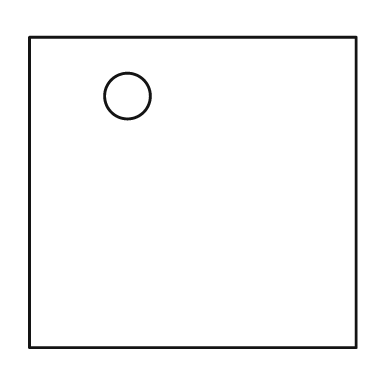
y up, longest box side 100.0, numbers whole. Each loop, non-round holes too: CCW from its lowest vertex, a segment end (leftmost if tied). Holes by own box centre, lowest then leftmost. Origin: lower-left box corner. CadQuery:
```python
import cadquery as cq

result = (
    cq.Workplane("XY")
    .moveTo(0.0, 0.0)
    .lineTo(100.0, 0.0)
    .lineTo(100.0, 95.0)
    .lineTo(0.0, 95.0)
    .close()
    .moveTo(30.0, 77.0)
    .circle(7.0)
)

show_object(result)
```